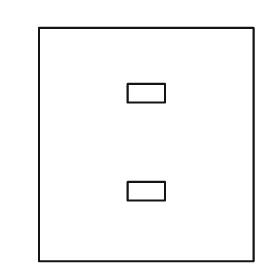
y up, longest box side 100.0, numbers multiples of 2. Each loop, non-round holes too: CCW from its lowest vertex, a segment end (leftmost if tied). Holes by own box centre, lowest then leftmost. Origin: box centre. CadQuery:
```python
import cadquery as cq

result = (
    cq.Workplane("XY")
    .moveTo(-46.0, -50.0)
    .lineTo(46.0, -50.0)
    .lineTo(46.0, 50.0)
    .lineTo(-46.0, 50.0)
    .close()
    .moveTo(-8.0, -24.0)
    .lineTo(8.0, -24.0)
    .lineTo(8.0, -16.0)
    .lineTo(-8.0, -16.0)
    .close()
    .moveTo(-8.0, 18.0)
    .lineTo(8.0, 18.0)
    .lineTo(8.0, 26.0)
    .lineTo(-8.0, 26.0)
    .close()
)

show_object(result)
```